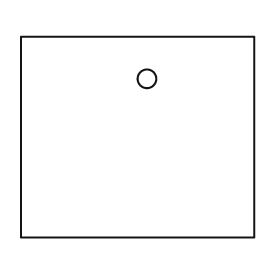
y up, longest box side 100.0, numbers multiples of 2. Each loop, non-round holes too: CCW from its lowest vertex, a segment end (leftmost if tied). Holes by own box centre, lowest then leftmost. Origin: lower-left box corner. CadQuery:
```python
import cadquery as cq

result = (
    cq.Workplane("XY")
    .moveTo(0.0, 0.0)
    .lineTo(100.0, 0.0)
    .lineTo(100.0, 86.0)
    .lineTo(0.0, 86.0)
    .close()
    .moveTo(54.0, 68.0)
    .circle(4.0)
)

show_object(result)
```